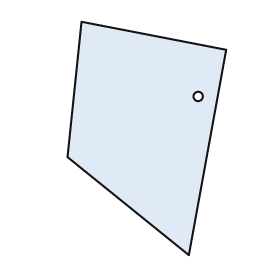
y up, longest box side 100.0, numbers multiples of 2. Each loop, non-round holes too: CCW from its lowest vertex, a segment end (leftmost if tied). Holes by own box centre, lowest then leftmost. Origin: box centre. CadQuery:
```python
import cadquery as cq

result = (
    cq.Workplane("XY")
    .moveTo(18.0, -50.0)
    .lineTo(34.0, 38.0)
    .lineTo(-28.0, 50.0)
    .lineTo(-34.0, -8.0)
    .close()
    .moveTo(22.0, 18.0)
    .circle(2.0)
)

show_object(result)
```